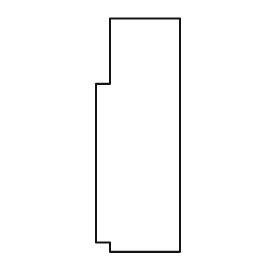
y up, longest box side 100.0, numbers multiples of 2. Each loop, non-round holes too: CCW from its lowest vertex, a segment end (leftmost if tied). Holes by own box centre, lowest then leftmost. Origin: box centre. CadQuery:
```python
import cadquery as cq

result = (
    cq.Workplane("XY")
    .moveTo(-12.0, -50.0)
    .lineTo(18.0, -50.0)
    .lineTo(18.0, 50.0)
    .lineTo(-12.0, 50.0)
    .lineTo(-12.0, 22.0)
    .lineTo(-18.0, 22.0)
    .lineTo(-18.0, -46.0)
    .lineTo(-12.0, -46.0)
    .close()
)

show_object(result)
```